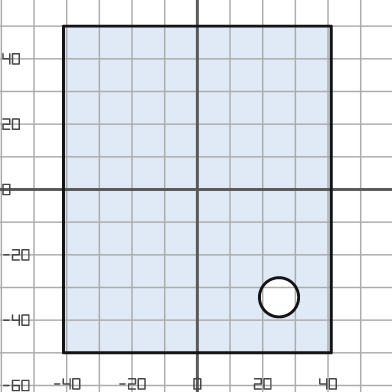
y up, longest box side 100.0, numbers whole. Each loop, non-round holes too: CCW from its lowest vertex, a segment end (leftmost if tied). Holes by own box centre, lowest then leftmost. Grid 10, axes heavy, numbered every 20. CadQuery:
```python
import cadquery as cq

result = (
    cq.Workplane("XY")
    .moveTo(-41.0, -50.0)
    .lineTo(41.0, -50.0)
    .lineTo(41.0, 50.0)
    .lineTo(-41.0, 50.0)
    .close()
    .moveTo(25.0, -33.0)
    .circle(6.0)
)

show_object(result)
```